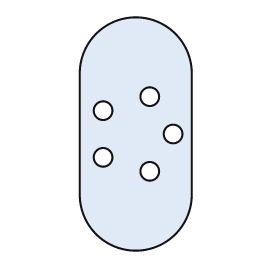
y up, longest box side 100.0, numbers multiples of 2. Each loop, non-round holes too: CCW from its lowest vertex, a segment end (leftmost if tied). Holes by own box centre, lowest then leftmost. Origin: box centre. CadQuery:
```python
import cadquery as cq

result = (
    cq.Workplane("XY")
    .moveTo(-24.0, -26.0)
    .threePointArc((0.0, -50.0), (24.0, -26.0))
    .lineTo(24.0, 26.0)
    .threePointArc((0.0, 50.0), (-24.0, 26.0))
    .close()
    .moveTo(6.0, -16.0)
    .circle(4.0)
    .moveTo(-14.0, -10.0)
    .circle(4.0)
    .moveTo(16.0, 0.0)
    .circle(4.0)
    .moveTo(-14.0, 10.0)
    .circle(4.0)
    .moveTo(6.0, 16.0)
    .circle(4.0)
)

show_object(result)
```